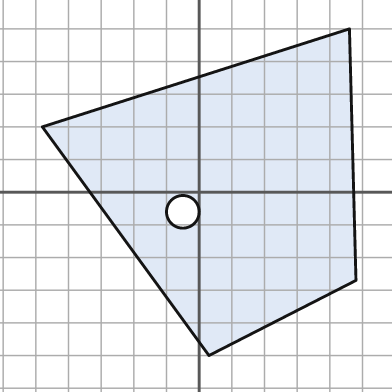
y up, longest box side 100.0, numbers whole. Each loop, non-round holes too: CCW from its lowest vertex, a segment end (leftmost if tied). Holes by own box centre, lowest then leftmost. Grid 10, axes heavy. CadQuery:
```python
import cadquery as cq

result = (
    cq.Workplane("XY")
    .moveTo(3.0, -50.0)
    .lineTo(48.0, -27.0)
    .lineTo(46.0, 50.0)
    .lineTo(-48.0, 20.0)
    .close()
    .moveTo(-5.0, -6.0)
    .circle(5.0)
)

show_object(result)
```